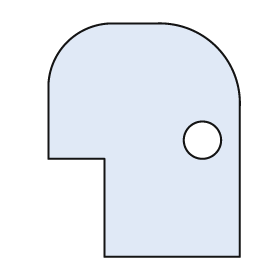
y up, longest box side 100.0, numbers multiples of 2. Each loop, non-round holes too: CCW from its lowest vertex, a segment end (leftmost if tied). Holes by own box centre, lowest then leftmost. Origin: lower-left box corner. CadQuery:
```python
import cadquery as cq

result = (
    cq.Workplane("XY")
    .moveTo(24.0, 0.0)
    .lineTo(82.0, 0.0)
    .lineTo(82.0, 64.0)
    .threePointArc((72.0, 90.0), (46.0, 100.0))
    .lineTo(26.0, 100.0)
    .threePointArc((8.0, 92.0), (0.0, 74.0))
    .lineTo(0.0, 42.0)
    .lineTo(24.0, 42.0)
    .close()
    .moveTo(66.0, 50.0)
    .circle(8.0)
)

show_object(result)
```